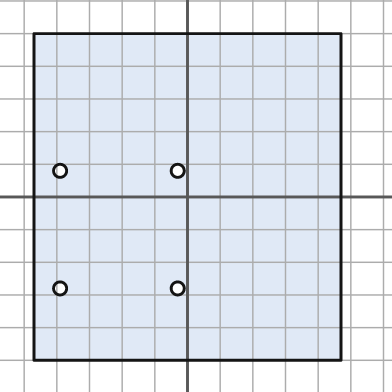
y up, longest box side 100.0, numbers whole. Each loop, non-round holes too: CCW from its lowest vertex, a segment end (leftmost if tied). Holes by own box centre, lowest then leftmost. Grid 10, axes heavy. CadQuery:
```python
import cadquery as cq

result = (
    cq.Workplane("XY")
    .moveTo(-47.0, -50.0)
    .lineTo(47.0, -50.0)
    .lineTo(47.0, 50.0)
    .lineTo(-47.0, 50.0)
    .close()
    .moveTo(-39.0, -28.0)
    .circle(2.0)
    .moveTo(-3.0, -28.0)
    .circle(2.0)
    .moveTo(-39.0, 8.0)
    .circle(2.0)
    .moveTo(-3.0, 8.0)
    .circle(2.0)
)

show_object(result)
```